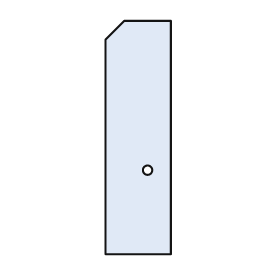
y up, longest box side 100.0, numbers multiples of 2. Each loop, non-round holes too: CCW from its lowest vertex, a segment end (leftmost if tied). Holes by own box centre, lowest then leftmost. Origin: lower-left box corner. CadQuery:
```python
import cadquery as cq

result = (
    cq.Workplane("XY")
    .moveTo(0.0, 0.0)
    .lineTo(28.0, 0.0)
    .lineTo(28.0, 100.0)
    .lineTo(8.0, 100.0)
    .lineTo(0.0, 92.0)
    .close()
    .moveTo(18.0, 36.0)
    .circle(2.0)
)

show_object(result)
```